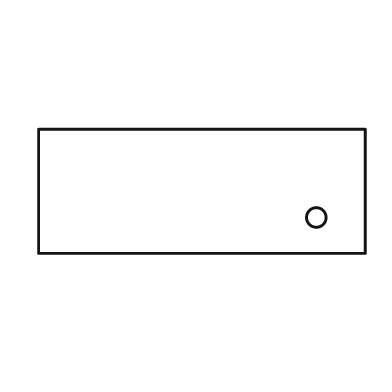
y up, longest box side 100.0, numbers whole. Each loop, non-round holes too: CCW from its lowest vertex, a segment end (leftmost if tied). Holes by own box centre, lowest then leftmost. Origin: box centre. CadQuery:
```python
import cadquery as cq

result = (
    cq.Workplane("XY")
    .moveTo(-50.0, -19.0)
    .lineTo(50.0, -19.0)
    .lineTo(50.0, 19.0)
    .lineTo(-50.0, 19.0)
    .close()
    .moveTo(35.0, -8.0)
    .circle(3.0)
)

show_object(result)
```